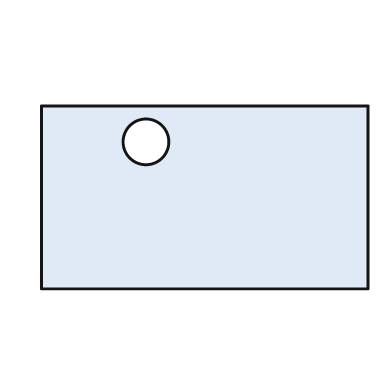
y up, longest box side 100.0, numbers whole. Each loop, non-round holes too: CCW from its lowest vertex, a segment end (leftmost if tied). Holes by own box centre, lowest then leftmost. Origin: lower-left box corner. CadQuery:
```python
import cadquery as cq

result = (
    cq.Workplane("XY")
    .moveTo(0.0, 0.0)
    .lineTo(100.0, 0.0)
    .lineTo(100.0, 56.0)
    .lineTo(0.0, 56.0)
    .close()
    .moveTo(32.0, 45.0)
    .circle(7.0)
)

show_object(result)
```